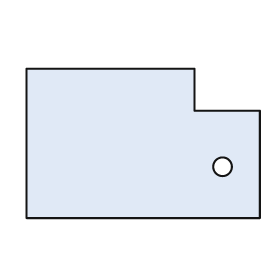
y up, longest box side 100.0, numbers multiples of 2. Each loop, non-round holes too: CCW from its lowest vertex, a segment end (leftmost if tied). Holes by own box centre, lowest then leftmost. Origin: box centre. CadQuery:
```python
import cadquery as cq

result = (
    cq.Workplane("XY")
    .moveTo(-50.0, -32.0)
    .lineTo(50.0, -32.0)
    .lineTo(50.0, 14.0)
    .lineTo(22.0, 14.0)
    .lineTo(22.0, 32.0)
    .lineTo(-50.0, 32.0)
    .close()
    .moveTo(34.0, -10.0)
    .circle(4.0)
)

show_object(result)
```